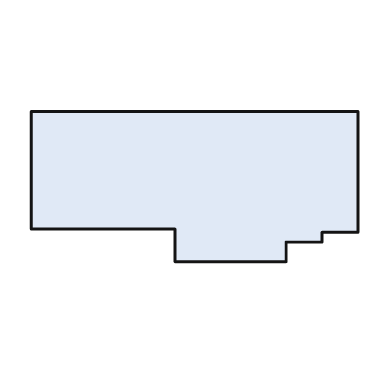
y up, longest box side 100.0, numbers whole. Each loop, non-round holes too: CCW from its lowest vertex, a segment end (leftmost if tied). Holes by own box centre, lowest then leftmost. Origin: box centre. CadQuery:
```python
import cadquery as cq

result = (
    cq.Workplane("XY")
    .moveTo(-6.0, -23.0)
    .lineTo(28.0, -23.0)
    .lineTo(28.0, -17.0)
    .lineTo(39.0, -17.0)
    .lineTo(39.0, -14.0)
    .lineTo(50.0, -14.0)
    .lineTo(50.0, 23.0)
    .lineTo(-50.0, 23.0)
    .lineTo(-50.0, -13.0)
    .lineTo(-6.0, -13.0)
    .close()
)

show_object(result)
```